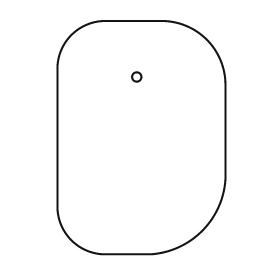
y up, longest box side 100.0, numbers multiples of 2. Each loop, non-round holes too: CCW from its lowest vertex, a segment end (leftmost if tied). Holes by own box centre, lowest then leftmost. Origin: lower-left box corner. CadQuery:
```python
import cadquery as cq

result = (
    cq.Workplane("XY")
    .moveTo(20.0, 0.0)
    .lineTo(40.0, 0.0)
    .threePointArc((62.0, 10.0), (72.0, 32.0))
    .lineTo(72.0, 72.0)
    .threePointArc((64.0, 92.0), (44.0, 100.0))
    .lineTo(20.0, 100.0)
    .threePointArc((6.0, 94.0), (0.0, 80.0))
    .lineTo(0.0, 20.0)
    .threePointArc((6.0, 6.0), (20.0, 0.0))
    .close()
    .moveTo(34.0, 76.0)
    .circle(2.0)
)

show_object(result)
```